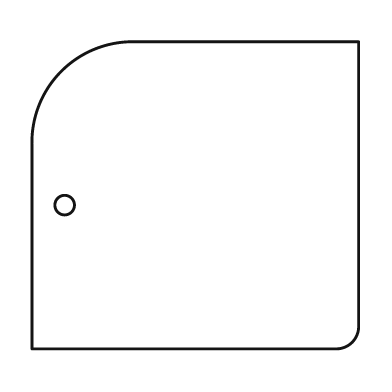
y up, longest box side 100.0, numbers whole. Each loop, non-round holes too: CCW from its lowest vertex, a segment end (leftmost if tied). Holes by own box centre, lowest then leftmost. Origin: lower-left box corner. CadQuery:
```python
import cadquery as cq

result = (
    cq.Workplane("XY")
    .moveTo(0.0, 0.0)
    .lineTo(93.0, 0.0)
    .threePointArc((98.0, 2.0), (100.0, 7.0))
    .lineTo(100.0, 94.0)
    .lineTo(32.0, 94.0)
    .threePointArc((9.0, 85.0), (0.0, 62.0))
    .close()
    .moveTo(10.0, 44.0)
    .circle(3.0)
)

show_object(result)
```